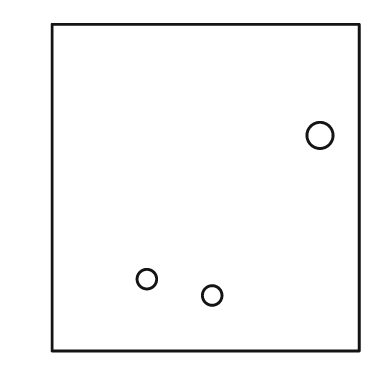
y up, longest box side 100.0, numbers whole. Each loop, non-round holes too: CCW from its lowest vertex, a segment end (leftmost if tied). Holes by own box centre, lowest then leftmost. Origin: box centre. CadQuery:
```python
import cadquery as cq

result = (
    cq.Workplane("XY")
    .moveTo(-47.0, -50.0)
    .lineTo(47.0, -50.0)
    .lineTo(47.0, 50.0)
    .lineTo(-47.0, 50.0)
    .close()
    .moveTo(2.0, -33.0)
    .circle(3.0)
    .moveTo(-18.0, -28.0)
    .circle(3.0)
    .moveTo(35.0, 16.0)
    .circle(4.0)
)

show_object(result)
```